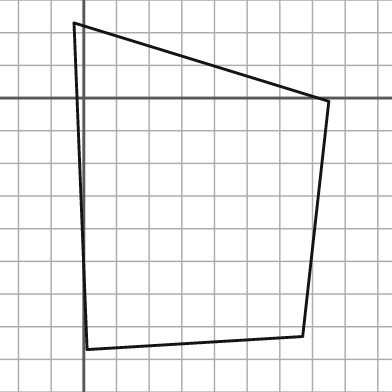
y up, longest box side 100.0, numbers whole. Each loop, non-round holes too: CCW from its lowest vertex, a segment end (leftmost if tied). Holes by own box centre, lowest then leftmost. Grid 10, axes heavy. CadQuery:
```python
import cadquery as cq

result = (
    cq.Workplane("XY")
    .moveTo(1.0, -77.0)
    .lineTo(67.0, -73.0)
    .lineTo(75.0, -1.0)
    .lineTo(-3.0, 23.0)
    .close()
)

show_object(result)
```